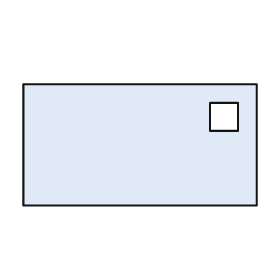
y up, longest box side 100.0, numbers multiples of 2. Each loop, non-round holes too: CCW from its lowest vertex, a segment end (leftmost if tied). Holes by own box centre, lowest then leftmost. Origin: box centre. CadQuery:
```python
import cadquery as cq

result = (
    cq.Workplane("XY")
    .moveTo(-50.0, -26.0)
    .lineTo(50.0, -26.0)
    .lineTo(50.0, 26.0)
    .lineTo(-50.0, 26.0)
    .close()
    .moveTo(30.0, 6.0)
    .lineTo(42.0, 6.0)
    .lineTo(42.0, 18.0)
    .lineTo(30.0, 18.0)
    .close()
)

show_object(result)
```